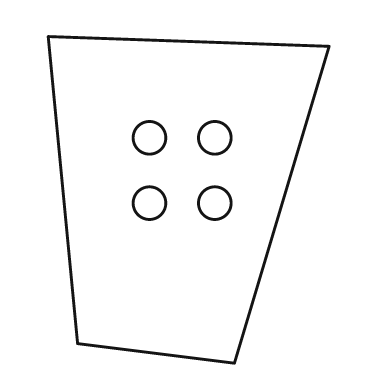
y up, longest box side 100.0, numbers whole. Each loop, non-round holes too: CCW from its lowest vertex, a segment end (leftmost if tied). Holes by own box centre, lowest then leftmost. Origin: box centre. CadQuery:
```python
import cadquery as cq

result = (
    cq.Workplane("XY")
    .moveTo(14.0, -50.0)
    .lineTo(43.0, 47.0)
    .lineTo(-43.0, 50.0)
    .lineTo(-34.0, -44.0)
    .close()
    .moveTo(-12.0, -1.0)
    .circle(5.0)
    .moveTo(8.0, -1.0)
    .circle(5.0)
    .moveTo(-12.0, 19.0)
    .circle(5.0)
    .moveTo(8.0, 19.0)
    .circle(5.0)
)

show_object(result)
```